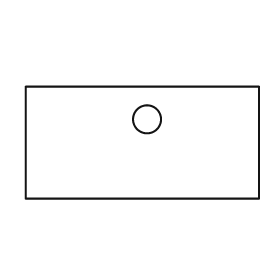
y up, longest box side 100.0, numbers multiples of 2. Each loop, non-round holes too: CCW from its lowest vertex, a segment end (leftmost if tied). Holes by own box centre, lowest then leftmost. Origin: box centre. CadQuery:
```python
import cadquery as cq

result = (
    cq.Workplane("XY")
    .moveTo(-50.0, -24.0)
    .lineTo(50.0, -24.0)
    .lineTo(50.0, 24.0)
    .lineTo(-50.0, 24.0)
    .close()
    .moveTo(2.0, 10.0)
    .circle(6.0)
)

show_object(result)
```